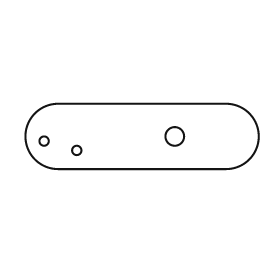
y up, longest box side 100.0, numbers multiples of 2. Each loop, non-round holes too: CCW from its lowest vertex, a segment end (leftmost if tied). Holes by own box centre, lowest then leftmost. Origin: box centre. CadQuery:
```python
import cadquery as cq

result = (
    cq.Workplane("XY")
    .moveTo(-36.0, -14.0)
    .lineTo(36.0, -14.0)
    .threePointArc((50.0, 0.0), (36.0, 14.0))
    .lineTo(-36.0, 14.0)
    .threePointArc((-50.0, 0.0), (-36.0, -14.0))
    .close()
    .moveTo(-28.0, -6.0)
    .circle(2.0)
    .moveTo(-42.0, -2.0)
    .circle(2.0)
    .moveTo(14.0, 0.0)
    .circle(4.0)
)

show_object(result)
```